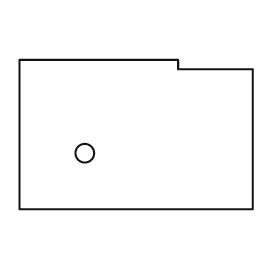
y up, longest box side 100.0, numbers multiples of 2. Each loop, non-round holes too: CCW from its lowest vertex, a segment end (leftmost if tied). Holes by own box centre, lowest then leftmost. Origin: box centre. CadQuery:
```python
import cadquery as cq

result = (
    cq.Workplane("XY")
    .moveTo(-50.0, -32.0)
    .lineTo(50.0, -32.0)
    .lineTo(50.0, 28.0)
    .lineTo(18.0, 28.0)
    .lineTo(18.0, 32.0)
    .lineTo(-50.0, 32.0)
    .close()
    .moveTo(-22.0, -8.0)
    .circle(4.0)
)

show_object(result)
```